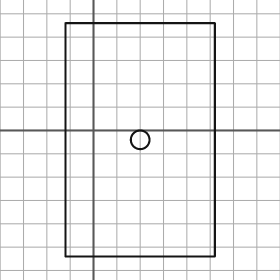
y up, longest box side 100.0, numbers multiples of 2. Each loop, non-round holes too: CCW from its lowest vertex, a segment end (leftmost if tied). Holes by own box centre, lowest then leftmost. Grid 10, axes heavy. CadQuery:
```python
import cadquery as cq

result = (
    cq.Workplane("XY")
    .moveTo(-12.0, -54.0)
    .lineTo(52.0, -54.0)
    .lineTo(52.0, 46.0)
    .lineTo(-12.0, 46.0)
    .close()
    .moveTo(20.0, -4.0)
    .circle(4.0)
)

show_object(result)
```